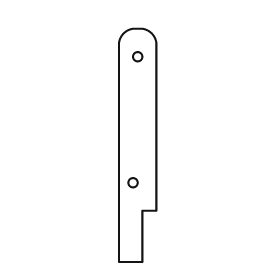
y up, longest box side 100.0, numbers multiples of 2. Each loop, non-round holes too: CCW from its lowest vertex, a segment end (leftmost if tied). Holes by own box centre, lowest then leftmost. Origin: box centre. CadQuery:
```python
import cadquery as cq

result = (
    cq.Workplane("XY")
    .moveTo(-8.0, -50.0)
    .lineTo(2.0, -50.0)
    .lineTo(2.0, -28.0)
    .lineTo(8.0, -28.0)
    .lineTo(8.0, 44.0)
    .threePointArc((6.0, 48.0), (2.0, 50.0))
    .lineTo(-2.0, 50.0)
    .threePointArc((-6.0, 48.0), (-8.0, 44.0))
    .close()
    .moveTo(-2.0, -16.0)
    .circle(2.0)
    .moveTo(0.0, 38.0)
    .circle(2.0)
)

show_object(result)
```